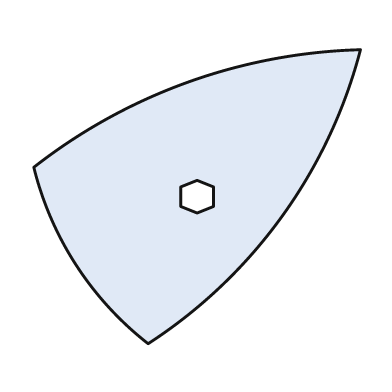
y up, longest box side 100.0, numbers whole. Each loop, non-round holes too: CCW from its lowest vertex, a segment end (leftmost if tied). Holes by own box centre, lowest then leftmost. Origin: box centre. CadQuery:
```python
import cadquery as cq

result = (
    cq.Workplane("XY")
    .moveTo(-15.0, -45.0)
    .threePointArc((26.0, -6.0), (50.0, 45.0))
    .threePointArc((-3.0, 35.0), (-50.0, 9.0))
    .threePointArc((-37.0, -21.0), (-15.0, -45.0))
    .close()
    .moveTo(0.0, -5.0)
    .lineTo(5.0, -3.0)
    .lineTo(5.0, 3.0)
    .lineTo(0.0, 5.0)
    .lineTo(-5.0, 3.0)
    .lineTo(-5.0, -3.0)
    .close()
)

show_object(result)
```